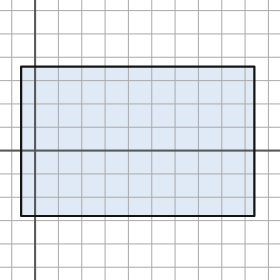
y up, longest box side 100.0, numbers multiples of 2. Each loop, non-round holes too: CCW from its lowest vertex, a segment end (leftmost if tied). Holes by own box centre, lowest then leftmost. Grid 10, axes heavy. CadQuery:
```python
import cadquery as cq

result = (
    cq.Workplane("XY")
    .moveTo(-6.0, -28.0)
    .lineTo(94.0, -28.0)
    .lineTo(94.0, 36.0)
    .lineTo(-6.0, 36.0)
    .close()
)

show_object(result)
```